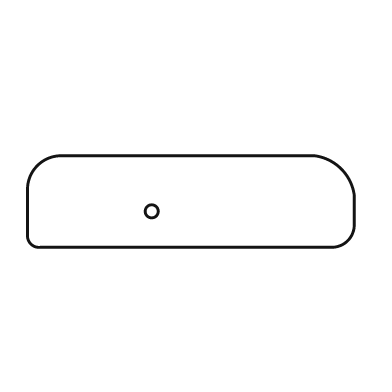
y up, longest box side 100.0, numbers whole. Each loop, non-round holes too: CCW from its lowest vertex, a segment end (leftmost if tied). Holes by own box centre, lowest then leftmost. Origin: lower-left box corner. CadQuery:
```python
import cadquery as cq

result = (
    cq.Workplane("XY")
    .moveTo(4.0, 0.0)
    .lineTo(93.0, 0.0)
    .threePointArc((98.0, 2.0), (100.0, 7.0))
    .lineTo(100.0, 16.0)
    .threePointArc((96.0, 24.0), (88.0, 28.0))
    .lineTo(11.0, 28.0)
    .threePointArc((3.0, 25.0), (0.0, 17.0))
    .lineTo(0.0, 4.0)
    .threePointArc((1.0, 1.0), (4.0, 0.0))
    .close()
    .moveTo(38.0, 11.0)
    .circle(2.0)
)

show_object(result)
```